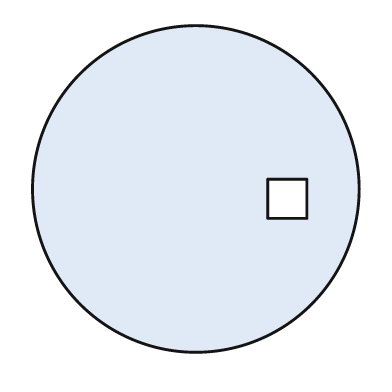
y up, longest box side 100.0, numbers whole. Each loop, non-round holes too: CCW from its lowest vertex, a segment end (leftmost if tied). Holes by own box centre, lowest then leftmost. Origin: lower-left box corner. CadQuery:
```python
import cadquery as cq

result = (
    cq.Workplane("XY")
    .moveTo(50.0, 50.0)
    .circle(50.0)
    .moveTo(72.0, 41.0)
    .lineTo(84.0, 41.0)
    .lineTo(84.0, 53.0)
    .lineTo(72.0, 53.0)
    .close()
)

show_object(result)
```